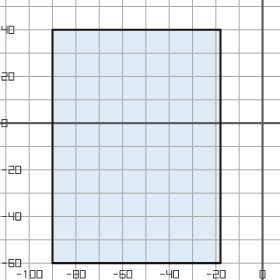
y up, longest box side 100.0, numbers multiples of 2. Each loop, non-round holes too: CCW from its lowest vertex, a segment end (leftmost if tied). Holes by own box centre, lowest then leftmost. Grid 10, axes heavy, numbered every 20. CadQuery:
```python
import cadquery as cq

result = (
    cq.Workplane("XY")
    .moveTo(-90.0, -60.0)
    .lineTo(-18.0, -60.0)
    .lineTo(-18.0, 40.0)
    .lineTo(-90.0, 40.0)
    .close()
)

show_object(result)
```